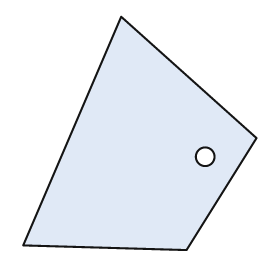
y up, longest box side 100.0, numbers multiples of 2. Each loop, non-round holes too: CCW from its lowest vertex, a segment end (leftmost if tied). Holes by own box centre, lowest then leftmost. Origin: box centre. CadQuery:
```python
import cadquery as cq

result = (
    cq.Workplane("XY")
    .moveTo(20.0, -50.0)
    .lineTo(50.0, -2.0)
    .lineTo(-8.0, 50.0)
    .lineTo(-50.0, -48.0)
    .close()
    .moveTo(28.0, -10.0)
    .circle(4.0)
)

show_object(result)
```